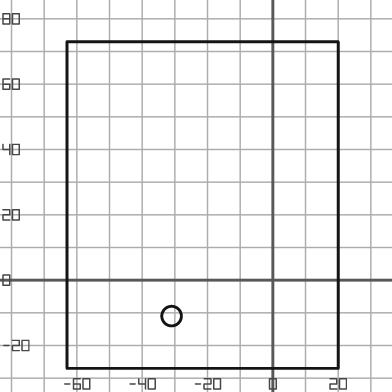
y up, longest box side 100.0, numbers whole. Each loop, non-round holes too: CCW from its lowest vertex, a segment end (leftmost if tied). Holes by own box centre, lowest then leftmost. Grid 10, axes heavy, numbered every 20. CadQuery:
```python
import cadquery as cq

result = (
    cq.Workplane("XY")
    .moveTo(-63.0, -27.0)
    .lineTo(20.0, -27.0)
    .lineTo(20.0, 73.0)
    .lineTo(-63.0, 73.0)
    .close()
    .moveTo(-31.0, -11.0)
    .circle(3.0)
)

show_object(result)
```